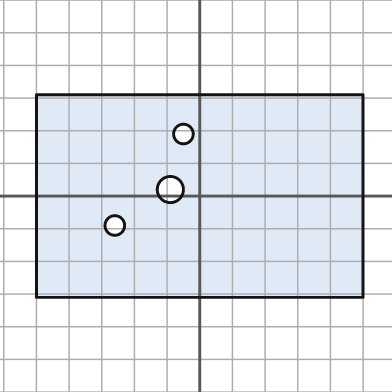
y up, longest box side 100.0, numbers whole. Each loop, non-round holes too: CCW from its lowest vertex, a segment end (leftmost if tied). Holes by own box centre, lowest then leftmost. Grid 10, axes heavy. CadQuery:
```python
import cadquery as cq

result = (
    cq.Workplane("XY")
    .moveTo(-50.0, -31.0)
    .lineTo(50.0, -31.0)
    .lineTo(50.0, 31.0)
    .lineTo(-50.0, 31.0)
    .close()
    .moveTo(-26.0, -9.0)
    .circle(3.0)
    .moveTo(-9.0, 2.0)
    .circle(4.0)
    .moveTo(-5.0, 19.0)
    .circle(3.0)
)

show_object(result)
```